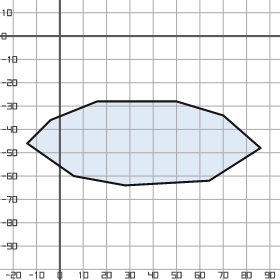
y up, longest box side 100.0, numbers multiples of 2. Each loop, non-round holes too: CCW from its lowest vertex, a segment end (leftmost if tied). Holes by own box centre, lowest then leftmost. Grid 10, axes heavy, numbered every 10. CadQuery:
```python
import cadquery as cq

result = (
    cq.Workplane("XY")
    .moveTo(28.0, -64.0)
    .lineTo(64.0, -62.0)
    .lineTo(86.0, -48.0)
    .lineTo(70.0, -34.0)
    .lineTo(50.0, -28.0)
    .lineTo(16.0, -28.0)
    .lineTo(-4.0, -36.0)
    .lineTo(-14.0, -46.0)
    .lineTo(6.0, -60.0)
    .close()
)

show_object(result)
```